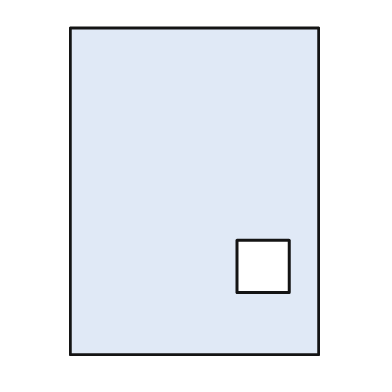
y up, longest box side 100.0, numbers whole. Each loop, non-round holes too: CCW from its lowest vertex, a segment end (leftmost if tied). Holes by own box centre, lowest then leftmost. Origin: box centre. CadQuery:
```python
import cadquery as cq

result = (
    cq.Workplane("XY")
    .moveTo(-38.0, -50.0)
    .lineTo(38.0, -50.0)
    .lineTo(38.0, 50.0)
    .lineTo(-38.0, 50.0)
    .close()
    .moveTo(13.0, -31.0)
    .lineTo(29.0, -31.0)
    .lineTo(29.0, -15.0)
    .lineTo(13.0, -15.0)
    .close()
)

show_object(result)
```